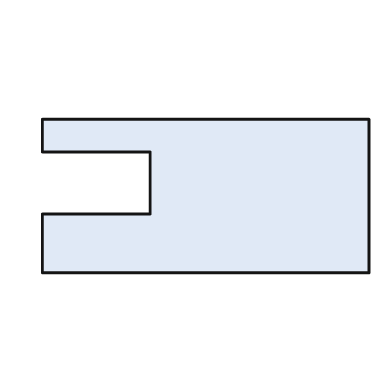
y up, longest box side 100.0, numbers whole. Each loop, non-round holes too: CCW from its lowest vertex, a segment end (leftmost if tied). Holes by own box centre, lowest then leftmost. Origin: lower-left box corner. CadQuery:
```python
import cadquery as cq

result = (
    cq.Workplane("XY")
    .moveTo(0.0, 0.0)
    .lineTo(100.0, 0.0)
    .lineTo(100.0, 47.0)
    .lineTo(0.0, 47.0)
    .lineTo(0.0, 37.0)
    .lineTo(33.0, 37.0)
    .lineTo(33.0, 18.0)
    .lineTo(0.0, 18.0)
    .close()
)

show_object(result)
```